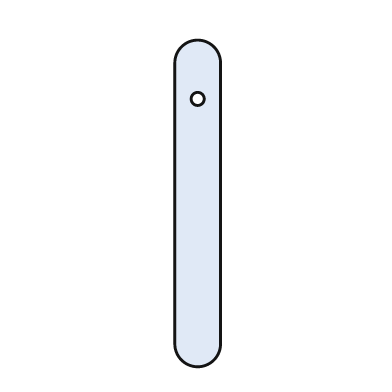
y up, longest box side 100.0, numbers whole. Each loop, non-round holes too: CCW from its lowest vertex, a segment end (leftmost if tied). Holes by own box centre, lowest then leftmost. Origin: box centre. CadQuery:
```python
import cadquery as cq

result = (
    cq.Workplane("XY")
    .moveTo(-7.0, -43.0)
    .threePointArc((0.0, -50.0), (7.0, -43.0))
    .lineTo(7.0, 43.0)
    .threePointArc((0.0, 50.0), (-7.0, 43.0))
    .close()
    .moveTo(0.0, 32.0)
    .circle(2.0)
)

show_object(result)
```